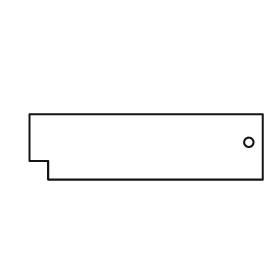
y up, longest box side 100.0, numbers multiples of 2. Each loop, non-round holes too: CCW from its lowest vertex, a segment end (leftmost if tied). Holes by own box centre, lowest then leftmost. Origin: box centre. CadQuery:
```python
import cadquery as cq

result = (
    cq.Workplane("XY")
    .moveTo(-42.0, -14.0)
    .lineTo(50.0, -14.0)
    .lineTo(50.0, 14.0)
    .lineTo(-50.0, 14.0)
    .lineTo(-50.0, -6.0)
    .lineTo(-42.0, -6.0)
    .close()
    .moveTo(44.0, 2.0)
    .circle(2.0)
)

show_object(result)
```